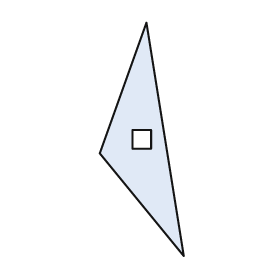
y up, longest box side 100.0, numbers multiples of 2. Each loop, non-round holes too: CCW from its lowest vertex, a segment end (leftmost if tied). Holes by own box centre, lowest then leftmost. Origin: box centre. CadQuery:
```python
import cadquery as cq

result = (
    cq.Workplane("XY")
    .moveTo(18.0, -50.0)
    .lineTo(2.0, 50.0)
    .lineTo(-18.0, -6.0)
    .close()
    .moveTo(-4.0, -4.0)
    .lineTo(4.0, -4.0)
    .lineTo(4.0, 4.0)
    .lineTo(-4.0, 4.0)
    .close()
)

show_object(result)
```